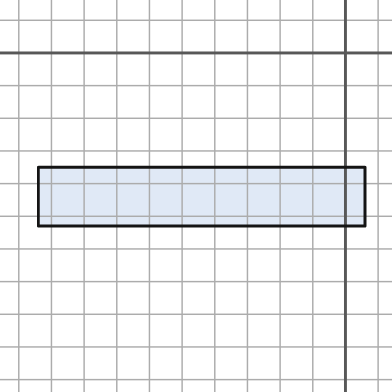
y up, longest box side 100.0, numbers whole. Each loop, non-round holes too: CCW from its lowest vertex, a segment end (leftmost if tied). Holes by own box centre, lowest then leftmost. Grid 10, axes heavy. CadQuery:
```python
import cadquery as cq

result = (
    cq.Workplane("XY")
    .moveTo(-94.0, -53.0)
    .lineTo(6.0, -53.0)
    .lineTo(6.0, -35.0)
    .lineTo(-94.0, -35.0)
    .close()
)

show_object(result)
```